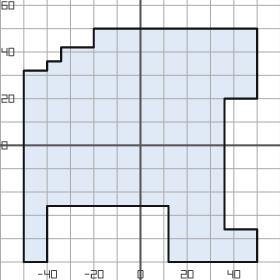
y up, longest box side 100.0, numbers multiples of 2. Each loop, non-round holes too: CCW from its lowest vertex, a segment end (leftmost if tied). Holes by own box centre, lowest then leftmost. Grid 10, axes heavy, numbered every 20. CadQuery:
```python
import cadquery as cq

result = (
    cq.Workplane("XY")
    .moveTo(-50.0, -50.0)
    .lineTo(-40.0, -50.0)
    .lineTo(-40.0, -26.0)
    .lineTo(12.0, -26.0)
    .lineTo(12.0, -50.0)
    .lineTo(50.0, -50.0)
    .lineTo(50.0, -36.0)
    .lineTo(36.0, -36.0)
    .lineTo(36.0, 20.0)
    .lineTo(50.0, 20.0)
    .lineTo(50.0, 50.0)
    .lineTo(-20.0, 50.0)
    .lineTo(-20.0, 42.0)
    .lineTo(-34.0, 42.0)
    .lineTo(-34.0, 36.0)
    .lineTo(-40.0, 36.0)
    .lineTo(-40.0, 32.0)
    .lineTo(-50.0, 32.0)
    .close()
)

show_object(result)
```